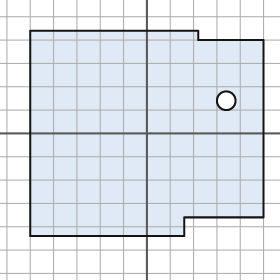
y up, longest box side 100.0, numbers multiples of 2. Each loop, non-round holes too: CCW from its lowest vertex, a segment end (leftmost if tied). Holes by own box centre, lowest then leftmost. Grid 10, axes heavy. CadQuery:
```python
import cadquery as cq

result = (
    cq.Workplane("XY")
    .moveTo(-50.0, -44.0)
    .lineTo(16.0, -44.0)
    .lineTo(16.0, -36.0)
    .lineTo(50.0, -36.0)
    .lineTo(50.0, 40.0)
    .lineTo(22.0, 40.0)
    .lineTo(22.0, 44.0)
    .lineTo(-50.0, 44.0)
    .close()
    .moveTo(34.0, 14.0)
    .circle(4.0)
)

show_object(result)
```